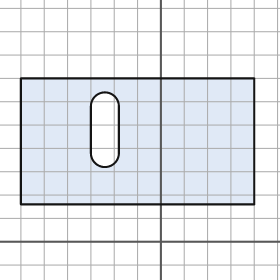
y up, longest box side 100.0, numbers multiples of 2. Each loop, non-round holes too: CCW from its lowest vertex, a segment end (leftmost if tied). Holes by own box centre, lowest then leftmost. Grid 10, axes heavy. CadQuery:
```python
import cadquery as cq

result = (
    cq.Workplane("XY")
    .moveTo(-60.0, 16.0)
    .lineTo(40.0, 16.0)
    .lineTo(40.0, 70.0)
    .lineTo(-60.0, 70.0)
    .close()
    .moveTo(-30.0, 38.0)
    .threePointArc((-24.0, 32.0), (-18.0, 38.0))
    .lineTo(-18.0, 58.0)
    .threePointArc((-24.0, 64.0), (-30.0, 58.0))
    .close()
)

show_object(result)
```